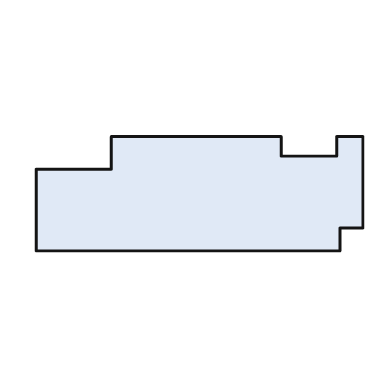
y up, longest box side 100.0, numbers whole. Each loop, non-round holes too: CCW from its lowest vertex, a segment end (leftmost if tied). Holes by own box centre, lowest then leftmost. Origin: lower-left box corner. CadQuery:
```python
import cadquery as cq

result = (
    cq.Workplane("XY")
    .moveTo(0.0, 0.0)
    .lineTo(93.0, 0.0)
    .lineTo(93.0, 7.0)
    .lineTo(100.0, 7.0)
    .lineTo(100.0, 35.0)
    .lineTo(92.0, 35.0)
    .lineTo(92.0, 29.0)
    .lineTo(75.0, 29.0)
    .lineTo(75.0, 35.0)
    .lineTo(23.0, 35.0)
    .lineTo(23.0, 25.0)
    .lineTo(0.0, 25.0)
    .close()
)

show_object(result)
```